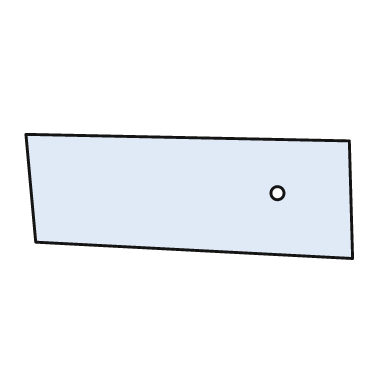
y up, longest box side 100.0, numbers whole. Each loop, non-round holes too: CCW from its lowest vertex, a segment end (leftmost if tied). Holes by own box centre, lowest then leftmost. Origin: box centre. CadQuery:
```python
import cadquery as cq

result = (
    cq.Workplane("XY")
    .moveTo(50.0, -19.0)
    .lineTo(49.0, 17.0)
    .lineTo(-50.0, 19.0)
    .lineTo(-47.0, -14.0)
    .close()
    .moveTo(27.0, 1.0)
    .circle(2.0)
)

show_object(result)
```